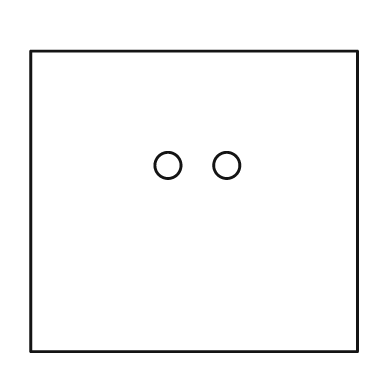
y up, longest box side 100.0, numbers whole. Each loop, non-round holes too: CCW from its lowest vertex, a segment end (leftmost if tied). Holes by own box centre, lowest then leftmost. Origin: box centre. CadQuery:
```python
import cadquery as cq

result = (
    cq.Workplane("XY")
    .moveTo(-50.0, -46.0)
    .lineTo(50.0, -46.0)
    .lineTo(50.0, 46.0)
    .lineTo(-50.0, 46.0)
    .close()
    .moveTo(-8.0, 11.0)
    .circle(4.0)
    .moveTo(10.0, 11.0)
    .circle(4.0)
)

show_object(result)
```